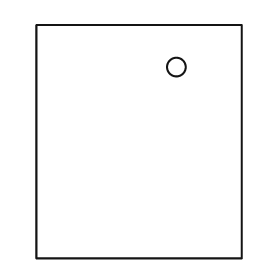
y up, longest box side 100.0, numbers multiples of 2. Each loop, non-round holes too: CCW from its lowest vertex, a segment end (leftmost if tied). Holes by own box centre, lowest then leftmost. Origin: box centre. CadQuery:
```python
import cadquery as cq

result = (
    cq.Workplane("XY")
    .moveTo(-44.0, -50.0)
    .lineTo(44.0, -50.0)
    .lineTo(44.0, 50.0)
    .lineTo(-44.0, 50.0)
    .close()
    .moveTo(16.0, 32.0)
    .circle(4.0)
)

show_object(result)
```